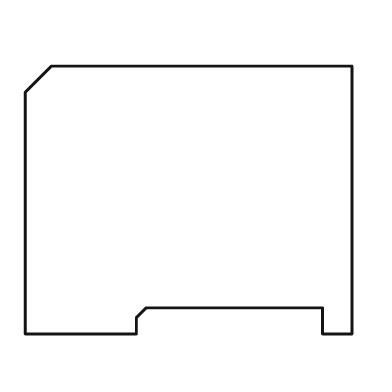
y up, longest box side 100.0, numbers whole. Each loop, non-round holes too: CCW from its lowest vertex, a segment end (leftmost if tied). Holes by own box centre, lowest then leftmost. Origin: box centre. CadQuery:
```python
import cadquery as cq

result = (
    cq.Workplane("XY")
    .moveTo(-50.0, -41.0)
    .lineTo(-16.0, -41.0)
    .lineTo(-16.0, -36.0)
    .lineTo(-13.0, -33.0)
    .lineTo(41.0, -33.0)
    .lineTo(41.0, -41.0)
    .lineTo(50.0, -41.0)
    .lineTo(50.0, 41.0)
    .lineTo(-42.0, 41.0)
    .lineTo(-50.0, 33.0)
    .close()
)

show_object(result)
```